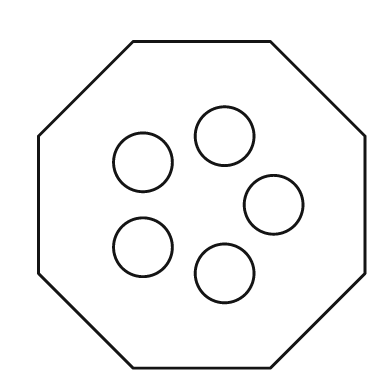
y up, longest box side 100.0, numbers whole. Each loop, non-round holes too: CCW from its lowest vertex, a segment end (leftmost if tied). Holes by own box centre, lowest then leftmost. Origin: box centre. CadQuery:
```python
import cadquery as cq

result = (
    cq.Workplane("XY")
    .moveTo(-21.0, -50.0)
    .lineTo(21.0, -50.0)
    .lineTo(50.0, -21.0)
    .lineTo(50.0, 21.0)
    .lineTo(21.0, 50.0)
    .lineTo(-21.0, 50.0)
    .lineTo(-50.0, 21.0)
    .lineTo(-50.0, -21.0)
    .close()
    .moveTo(7.0, -21.0)
    .circle(9.0)
    .moveTo(-18.0, -13.0)
    .circle(9.0)
    .moveTo(22.0, 0.0)
    .circle(9.0)
    .moveTo(-18.0, 13.0)
    .circle(9.0)
    .moveTo(7.0, 21.0)
    .circle(9.0)
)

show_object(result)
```